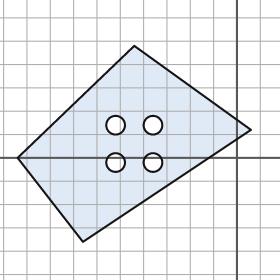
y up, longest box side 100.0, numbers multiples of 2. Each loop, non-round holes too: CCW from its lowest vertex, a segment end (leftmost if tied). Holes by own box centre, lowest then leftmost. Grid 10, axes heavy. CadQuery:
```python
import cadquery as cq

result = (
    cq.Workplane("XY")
    .moveTo(-66.0, -36.0)
    .lineTo(6.0, 12.0)
    .lineTo(-44.0, 48.0)
    .lineTo(-94.0, 0.0)
    .close()
    .moveTo(-52.0, -2.0)
    .circle(4.0)
    .moveTo(-36.0, -2.0)
    .circle(4.0)
    .moveTo(-52.0, 14.0)
    .circle(4.0)
    .moveTo(-36.0, 14.0)
    .circle(4.0)
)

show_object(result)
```